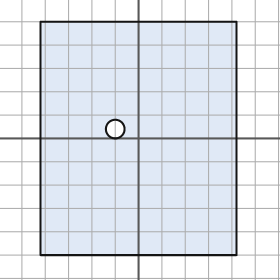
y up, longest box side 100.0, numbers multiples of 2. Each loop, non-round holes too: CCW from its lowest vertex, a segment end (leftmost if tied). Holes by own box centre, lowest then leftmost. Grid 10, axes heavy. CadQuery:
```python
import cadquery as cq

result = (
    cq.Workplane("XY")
    .moveTo(-42.0, -50.0)
    .lineTo(42.0, -50.0)
    .lineTo(42.0, 50.0)
    .lineTo(-42.0, 50.0)
    .close()
    .moveTo(-10.0, 4.0)
    .circle(4.0)
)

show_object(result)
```